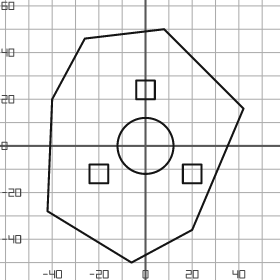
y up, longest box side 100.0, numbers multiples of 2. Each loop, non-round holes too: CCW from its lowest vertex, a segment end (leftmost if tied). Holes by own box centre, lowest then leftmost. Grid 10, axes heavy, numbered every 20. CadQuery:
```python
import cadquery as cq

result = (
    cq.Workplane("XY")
    .moveTo(-6.0, -50.0)
    .lineTo(20.0, -36.0)
    .lineTo(42.0, 16.0)
    .lineTo(8.0, 50.0)
    .lineTo(-26.0, 46.0)
    .lineTo(-40.0, 20.0)
    .lineTo(-42.0, -28.0)
    .close()
    .moveTo(-24.0, -16.0)
    .lineTo(-16.0, -16.0)
    .lineTo(-16.0, -8.0)
    .lineTo(-24.0, -8.0)
    .close()
    .moveTo(16.0, -16.0)
    .lineTo(24.0, -16.0)
    .lineTo(24.0, -8.0)
    .lineTo(16.0, -8.0)
    .close()
    .moveTo(0.0, 0.0)
    .circle(12.0)
    .moveTo(-4.0, 20.0)
    .lineTo(4.0, 20.0)
    .lineTo(4.0, 28.0)
    .lineTo(-4.0, 28.0)
    .close()
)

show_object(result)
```